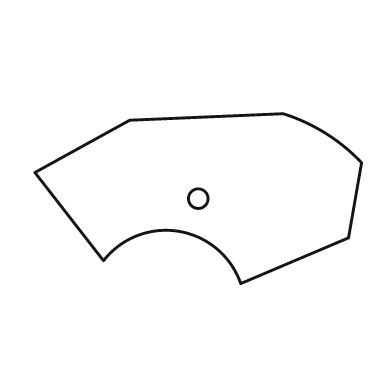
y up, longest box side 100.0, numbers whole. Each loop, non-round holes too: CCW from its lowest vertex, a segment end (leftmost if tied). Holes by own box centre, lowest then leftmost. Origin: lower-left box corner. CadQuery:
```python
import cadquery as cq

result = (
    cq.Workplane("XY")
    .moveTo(63.0, 0.0)
    .lineTo(96.0, 14.0)
    .lineTo(100.0, 37.0)
    .threePointArc((89.0, 46.0), (76.0, 52.0))
    .lineTo(29.0, 50.0)
    .lineTo(0.0, 34.0)
    .lineTo(21.0, 7.0)
    .threePointArc((44.0, 16.0), (63.0, 0.0))
    .close()
    .moveTo(50.0, 26.0)
    .circle(3.0)
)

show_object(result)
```